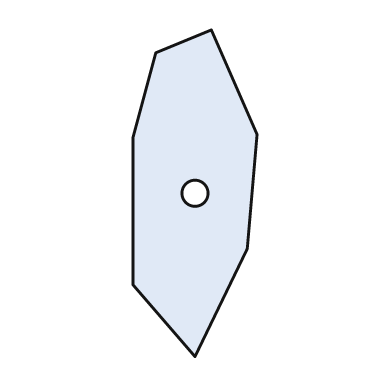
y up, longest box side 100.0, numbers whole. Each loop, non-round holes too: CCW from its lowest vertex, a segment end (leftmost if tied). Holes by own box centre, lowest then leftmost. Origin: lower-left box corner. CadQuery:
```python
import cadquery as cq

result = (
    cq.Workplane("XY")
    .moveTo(19.0, 0.0)
    .lineTo(35.0, 33.0)
    .lineTo(38.0, 68.0)
    .lineTo(24.0, 100.0)
    .lineTo(7.0, 93.0)
    .lineTo(0.0, 67.0)
    .lineTo(0.0, 22.0)
    .close()
    .moveTo(19.0, 50.0)
    .circle(4.0)
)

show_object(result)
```